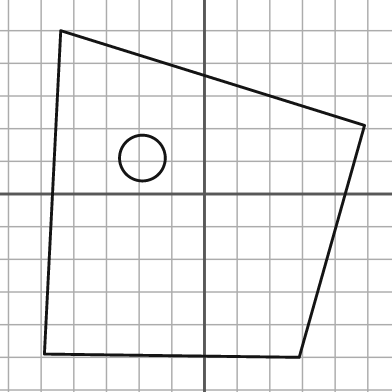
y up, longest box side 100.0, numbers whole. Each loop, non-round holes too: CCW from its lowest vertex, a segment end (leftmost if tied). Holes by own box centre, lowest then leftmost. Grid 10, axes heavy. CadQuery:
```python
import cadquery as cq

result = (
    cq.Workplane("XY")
    .moveTo(29.0, -50.0)
    .lineTo(49.0, 21.0)
    .lineTo(-44.0, 50.0)
    .lineTo(-49.0, -49.0)
    .close()
    .moveTo(-19.0, 11.0)
    .circle(7.0)
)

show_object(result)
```